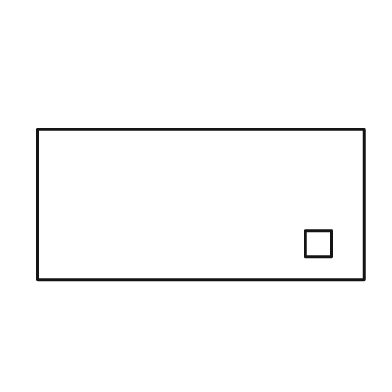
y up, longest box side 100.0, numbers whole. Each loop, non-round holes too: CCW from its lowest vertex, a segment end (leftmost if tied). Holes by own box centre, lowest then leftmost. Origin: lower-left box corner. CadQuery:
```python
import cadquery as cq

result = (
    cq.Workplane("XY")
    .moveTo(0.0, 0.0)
    .lineTo(100.0, 0.0)
    .lineTo(100.0, 46.0)
    .lineTo(0.0, 46.0)
    .close()
    .moveTo(82.0, 7.0)
    .lineTo(90.0, 7.0)
    .lineTo(90.0, 15.0)
    .lineTo(82.0, 15.0)
    .close()
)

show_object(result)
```